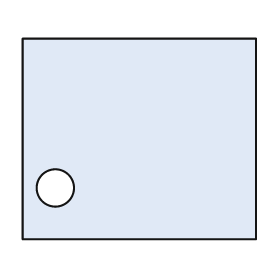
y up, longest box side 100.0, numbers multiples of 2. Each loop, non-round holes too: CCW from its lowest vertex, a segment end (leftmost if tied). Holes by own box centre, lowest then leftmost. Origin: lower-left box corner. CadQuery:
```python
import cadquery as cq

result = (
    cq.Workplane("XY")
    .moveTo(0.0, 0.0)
    .lineTo(100.0, 0.0)
    .lineTo(100.0, 86.0)
    .lineTo(0.0, 86.0)
    .close()
    .moveTo(14.0, 22.0)
    .circle(8.0)
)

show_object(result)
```